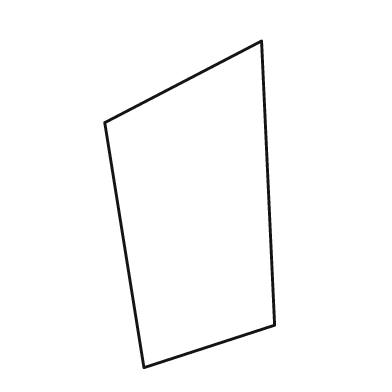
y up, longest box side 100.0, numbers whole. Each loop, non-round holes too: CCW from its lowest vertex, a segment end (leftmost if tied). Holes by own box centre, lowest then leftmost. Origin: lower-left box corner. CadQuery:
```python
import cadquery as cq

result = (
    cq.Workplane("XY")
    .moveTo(12.0, 0.0)
    .lineTo(52.0, 13.0)
    .lineTo(48.0, 100.0)
    .lineTo(0.0, 75.0)
    .close()
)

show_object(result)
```